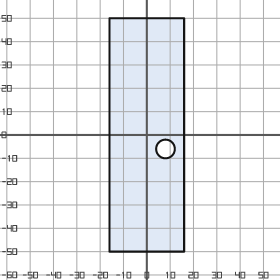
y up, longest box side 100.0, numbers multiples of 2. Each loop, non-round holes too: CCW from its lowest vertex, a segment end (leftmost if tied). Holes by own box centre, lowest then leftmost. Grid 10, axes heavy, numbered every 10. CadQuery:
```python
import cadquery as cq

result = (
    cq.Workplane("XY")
    .moveTo(-16.0, -50.0)
    .lineTo(16.0, -50.0)
    .lineTo(16.0, 50.0)
    .lineTo(-16.0, 50.0)
    .close()
    .moveTo(8.0, -6.0)
    .circle(4.0)
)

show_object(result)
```